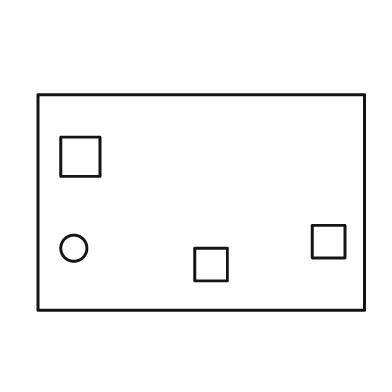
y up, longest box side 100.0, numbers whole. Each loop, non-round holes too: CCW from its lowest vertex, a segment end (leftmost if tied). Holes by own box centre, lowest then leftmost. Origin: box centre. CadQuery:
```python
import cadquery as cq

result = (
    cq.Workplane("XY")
    .moveTo(-50.0, -33.0)
    .lineTo(50.0, -33.0)
    .lineTo(50.0, 33.0)
    .lineTo(-50.0, 33.0)
    .close()
    .moveTo(-2.0, -24.0)
    .lineTo(8.0, -24.0)
    .lineTo(8.0, -14.0)
    .lineTo(-2.0, -14.0)
    .close()
    .moveTo(-39.0, -14.0)
    .circle(4.0)
    .moveTo(34.0, -17.0)
    .lineTo(44.0, -17.0)
    .lineTo(44.0, -7.0)
    .lineTo(34.0, -7.0)
    .close()
    .moveTo(-43.0, 8.0)
    .lineTo(-31.0, 8.0)
    .lineTo(-31.0, 20.0)
    .lineTo(-43.0, 20.0)
    .close()
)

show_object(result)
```